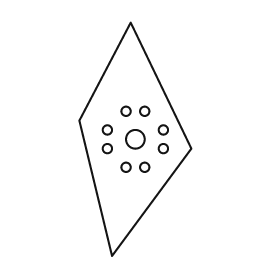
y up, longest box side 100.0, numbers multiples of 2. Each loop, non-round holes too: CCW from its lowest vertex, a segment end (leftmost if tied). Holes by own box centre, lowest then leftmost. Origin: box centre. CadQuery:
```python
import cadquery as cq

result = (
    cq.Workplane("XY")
    .moveTo(-10.0, -50.0)
    .lineTo(24.0, -4.0)
    .lineTo(-2.0, 50.0)
    .lineTo(-24.0, 8.0)
    .close()
    .moveTo(-4.0, -12.0)
    .circle(2.0)
    .moveTo(4.0, -12.0)
    .circle(2.0)
    .moveTo(-12.0, -4.0)
    .circle(2.0)
    .moveTo(12.0, -4.0)
    .circle(2.0)
    .moveTo(0.0, 0.0)
    .circle(4.0)
    .moveTo(-12.0, 4.0)
    .circle(2.0)
    .moveTo(12.0, 4.0)
    .circle(2.0)
    .moveTo(-4.0, 12.0)
    .circle(2.0)
    .moveTo(4.0, 12.0)
    .circle(2.0)
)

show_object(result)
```